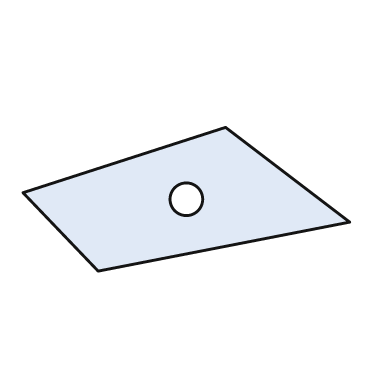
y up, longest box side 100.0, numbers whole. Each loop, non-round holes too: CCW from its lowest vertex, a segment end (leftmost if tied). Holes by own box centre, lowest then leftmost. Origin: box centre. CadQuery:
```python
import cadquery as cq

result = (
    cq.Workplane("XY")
    .moveTo(-27.0, -22.0)
    .lineTo(50.0, -7.0)
    .lineTo(12.0, 22.0)
    .lineTo(-50.0, 2.0)
    .close()
    .moveTo(0.0, 0.0)
    .circle(5.0)
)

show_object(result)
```